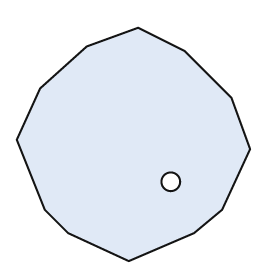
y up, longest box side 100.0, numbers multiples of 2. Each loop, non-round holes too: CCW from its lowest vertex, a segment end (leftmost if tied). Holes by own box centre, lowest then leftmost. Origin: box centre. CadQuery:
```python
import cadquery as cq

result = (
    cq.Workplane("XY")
    .moveTo(-2.0, -50.0)
    .lineTo(26.0, -38.0)
    .lineTo(38.0, -28.0)
    .lineTo(50.0, -2.0)
    .lineTo(42.0, 20.0)
    .lineTo(22.0, 40.0)
    .lineTo(2.0, 50.0)
    .lineTo(-20.0, 42.0)
    .lineTo(-40.0, 24.0)
    .lineTo(-50.0, 2.0)
    .lineTo(-38.0, -28.0)
    .lineTo(-28.0, -38.0)
    .close()
    .moveTo(16.0, -16.0)
    .circle(4.0)
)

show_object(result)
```